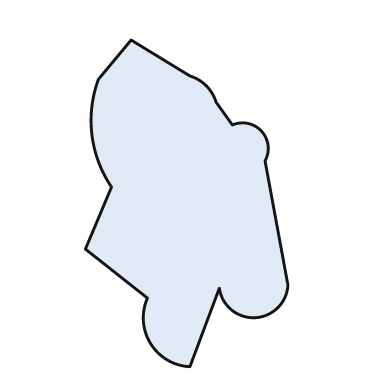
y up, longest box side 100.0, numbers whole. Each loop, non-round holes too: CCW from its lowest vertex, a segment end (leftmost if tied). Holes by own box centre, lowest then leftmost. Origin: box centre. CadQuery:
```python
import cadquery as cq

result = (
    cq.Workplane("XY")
    .moveTo(1.0, -50.0)
    .lineTo(10.0, -26.0)
    .threePointArc((21.0, -35.0), (31.0, -25.0))
    .lineTo(24.0, 13.0)
    .threePointArc((23.0, 22.0), (14.0, 24.0))
    .lineTo(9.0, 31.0)
    .threePointArc((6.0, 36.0), (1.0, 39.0))
    .lineTo(-17.0, 50.0)
    .lineTo(-27.0, 38.0)
    .threePointArc((-29.0, 21.0), (-23.0, 5.0))
    .lineTo(-31.0, -14.0)
    .lineTo(-12.0, -29.0)
    .threePointArc((-11.0, -43.0), (1.0, -50.0))
    .close()
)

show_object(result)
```